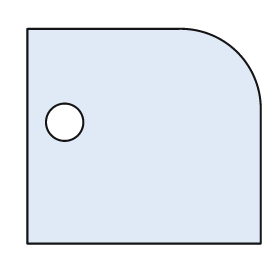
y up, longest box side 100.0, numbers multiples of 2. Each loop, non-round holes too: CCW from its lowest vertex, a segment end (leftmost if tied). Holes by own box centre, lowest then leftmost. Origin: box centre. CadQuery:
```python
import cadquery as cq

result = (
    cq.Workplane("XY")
    .moveTo(-50.0, -46.0)
    .lineTo(50.0, -46.0)
    .lineTo(50.0, 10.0)
    .threePointArc((40.0, 36.0), (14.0, 46.0))
    .lineTo(-50.0, 46.0)
    .close()
    .moveTo(-34.0, 6.0)
    .circle(8.0)
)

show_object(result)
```